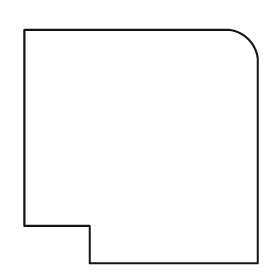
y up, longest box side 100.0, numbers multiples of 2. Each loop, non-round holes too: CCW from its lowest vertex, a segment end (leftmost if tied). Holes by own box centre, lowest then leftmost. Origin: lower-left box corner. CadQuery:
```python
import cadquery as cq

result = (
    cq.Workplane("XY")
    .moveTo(28.0, 0.0)
    .lineTo(100.0, 0.0)
    .lineTo(100.0, 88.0)
    .threePointArc((96.0, 96.0), (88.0, 100.0))
    .lineTo(0.0, 100.0)
    .lineTo(0.0, 16.0)
    .lineTo(28.0, 16.0)
    .close()
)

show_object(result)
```